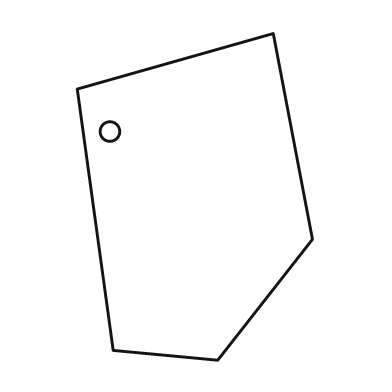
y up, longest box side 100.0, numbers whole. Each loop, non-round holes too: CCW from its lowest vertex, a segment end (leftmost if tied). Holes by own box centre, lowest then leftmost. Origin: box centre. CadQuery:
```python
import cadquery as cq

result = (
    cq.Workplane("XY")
    .moveTo(7.0, -50.0)
    .lineTo(36.0, -13.0)
    .lineTo(24.0, 50.0)
    .lineTo(-36.0, 33.0)
    .lineTo(-25.0, -47.0)
    .close()
    .moveTo(-26.0, 20.0)
    .circle(3.0)
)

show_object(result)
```